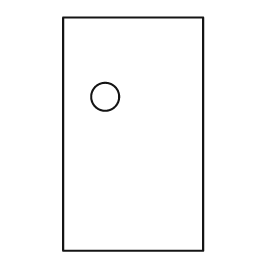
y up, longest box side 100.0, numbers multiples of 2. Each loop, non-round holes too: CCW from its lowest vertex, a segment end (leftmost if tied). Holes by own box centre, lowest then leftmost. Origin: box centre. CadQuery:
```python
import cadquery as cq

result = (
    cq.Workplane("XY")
    .moveTo(-30.0, -50.0)
    .lineTo(30.0, -50.0)
    .lineTo(30.0, 50.0)
    .lineTo(-30.0, 50.0)
    .close()
    .moveTo(-12.0, 16.0)
    .circle(6.0)
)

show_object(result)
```